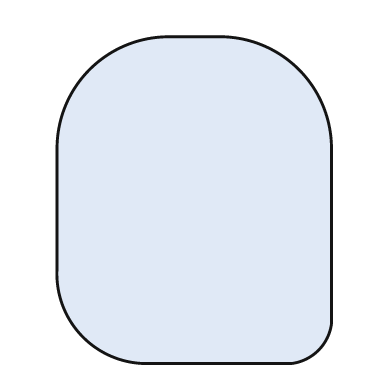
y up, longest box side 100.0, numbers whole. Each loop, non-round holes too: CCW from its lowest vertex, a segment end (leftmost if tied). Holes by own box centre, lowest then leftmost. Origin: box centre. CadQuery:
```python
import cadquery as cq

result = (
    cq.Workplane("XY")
    .moveTo(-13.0, -50.0)
    .lineTo(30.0, -50.0)
    .threePointArc((38.0, -46.0), (42.0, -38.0))
    .lineTo(42.0, 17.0)
    .threePointArc((32.0, 40.0), (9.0, 50.0))
    .lineTo(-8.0, 50.0)
    .threePointArc((-32.0, 40.0), (-42.0, 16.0))
    .lineTo(-42.0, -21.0)
    .threePointArc((-34.0, -42.0), (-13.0, -50.0))
    .close()
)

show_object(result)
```